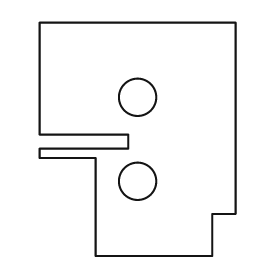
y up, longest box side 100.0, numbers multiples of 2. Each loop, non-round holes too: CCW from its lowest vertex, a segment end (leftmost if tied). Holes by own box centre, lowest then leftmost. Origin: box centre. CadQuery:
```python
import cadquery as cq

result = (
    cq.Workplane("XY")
    .moveTo(-18.0, -50.0)
    .lineTo(32.0, -50.0)
    .lineTo(32.0, -32.0)
    .lineTo(42.0, -32.0)
    .lineTo(42.0, 50.0)
    .lineTo(-42.0, 50.0)
    .lineTo(-42.0, 2.0)
    .lineTo(-4.0, 2.0)
    .lineTo(-4.0, -4.0)
    .lineTo(-42.0, -4.0)
    .lineTo(-42.0, -8.0)
    .lineTo(-18.0, -8.0)
    .close()
    .moveTo(0.0, -18.0)
    .circle(8.0)
    .moveTo(0.0, 18.0)
    .circle(8.0)
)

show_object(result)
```